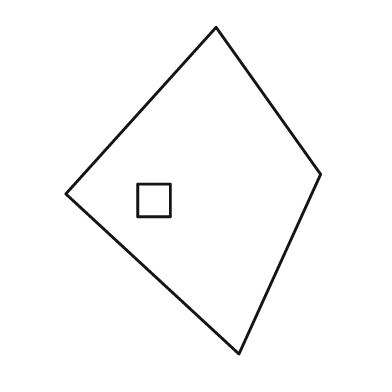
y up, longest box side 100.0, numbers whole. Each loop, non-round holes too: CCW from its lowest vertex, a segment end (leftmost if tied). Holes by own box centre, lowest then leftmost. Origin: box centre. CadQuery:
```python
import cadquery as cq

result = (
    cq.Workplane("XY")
    .moveTo(14.0, -50.0)
    .lineTo(39.0, 5.0)
    .lineTo(7.0, 50.0)
    .lineTo(-39.0, -1.0)
    .close()
    .moveTo(-17.0, -8.0)
    .lineTo(-7.0, -8.0)
    .lineTo(-7.0, 2.0)
    .lineTo(-17.0, 2.0)
    .close()
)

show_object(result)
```